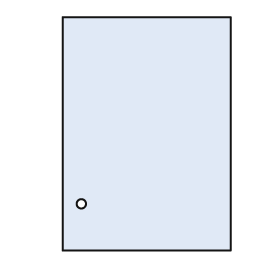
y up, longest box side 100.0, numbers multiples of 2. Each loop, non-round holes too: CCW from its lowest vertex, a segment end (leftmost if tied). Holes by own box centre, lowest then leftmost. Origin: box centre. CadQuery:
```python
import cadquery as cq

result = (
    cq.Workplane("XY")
    .moveTo(-36.0, -50.0)
    .lineTo(36.0, -50.0)
    .lineTo(36.0, 50.0)
    .lineTo(-36.0, 50.0)
    .close()
    .moveTo(-28.0, -30.0)
    .circle(2.0)
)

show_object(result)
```